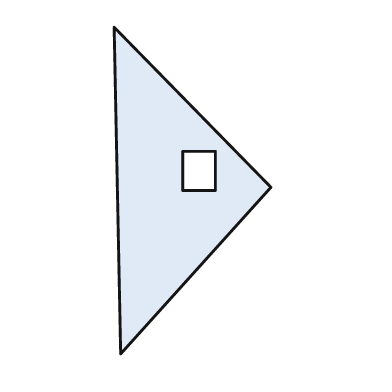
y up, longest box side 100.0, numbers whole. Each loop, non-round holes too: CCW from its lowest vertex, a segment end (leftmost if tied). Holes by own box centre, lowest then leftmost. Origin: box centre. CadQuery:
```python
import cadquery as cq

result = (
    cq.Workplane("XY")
    .moveTo(-22.0, -50.0)
    .lineTo(24.0, 1.0)
    .lineTo(-24.0, 50.0)
    .close()
    .moveTo(-3.0, 0.0)
    .lineTo(7.0, 0.0)
    .lineTo(7.0, 12.0)
    .lineTo(-3.0, 12.0)
    .close()
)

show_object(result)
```